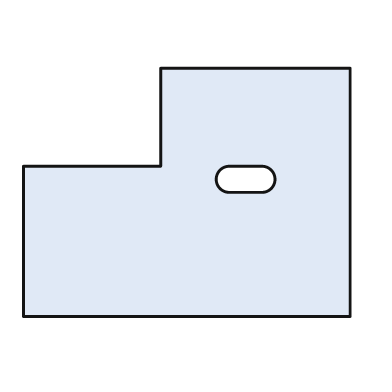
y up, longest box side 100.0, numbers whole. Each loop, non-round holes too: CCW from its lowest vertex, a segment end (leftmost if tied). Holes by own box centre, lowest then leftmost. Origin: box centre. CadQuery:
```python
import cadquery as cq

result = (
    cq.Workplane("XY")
    .moveTo(-50.0, -38.0)
    .lineTo(50.0, -38.0)
    .lineTo(50.0, 38.0)
    .lineTo(-8.0, 38.0)
    .lineTo(-8.0, 8.0)
    .lineTo(-50.0, 8.0)
    .close()
    .moveTo(13.0, 0.0)
    .lineTo(23.0, 0.0)
    .threePointArc((27.0, 4.0), (23.0, 8.0))
    .lineTo(13.0, 8.0)
    .threePointArc((9.0, 4.0), (13.0, 0.0))
    .close()
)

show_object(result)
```